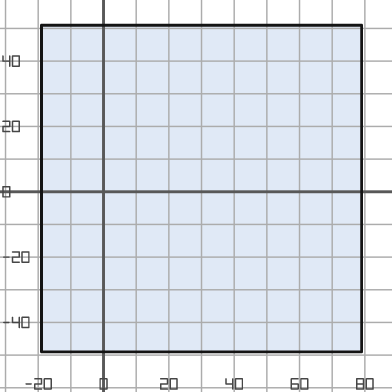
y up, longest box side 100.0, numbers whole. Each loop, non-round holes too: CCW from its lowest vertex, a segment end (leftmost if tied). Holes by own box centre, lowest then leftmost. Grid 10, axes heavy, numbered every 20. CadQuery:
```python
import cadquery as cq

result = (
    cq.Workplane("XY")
    .moveTo(-19.0, -49.0)
    .lineTo(79.0, -49.0)
    .lineTo(79.0, 51.0)
    .lineTo(-19.0, 51.0)
    .close()
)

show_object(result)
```